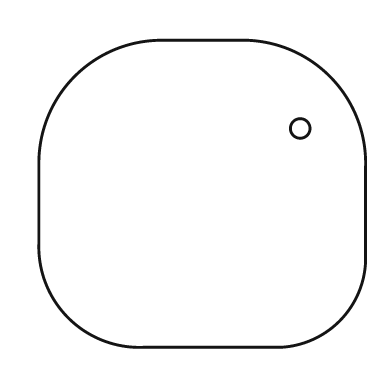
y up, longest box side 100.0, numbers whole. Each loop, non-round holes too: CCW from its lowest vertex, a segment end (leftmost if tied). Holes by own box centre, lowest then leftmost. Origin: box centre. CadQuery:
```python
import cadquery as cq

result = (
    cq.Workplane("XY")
    .moveTo(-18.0, -47.0)
    .lineTo(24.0, -47.0)
    .threePointArc((42.0, -39.0), (50.0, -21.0))
    .lineTo(50.0, 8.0)
    .threePointArc((39.0, 36.0), (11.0, 47.0))
    .lineTo(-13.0, 47.0)
    .threePointArc((-39.0, 36.0), (-50.0, 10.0))
    .lineTo(-50.0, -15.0)
    .threePointArc((-41.0, -38.0), (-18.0, -47.0))
    .close()
    .moveTo(30.0, 20.0)
    .circle(3.0)
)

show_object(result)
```